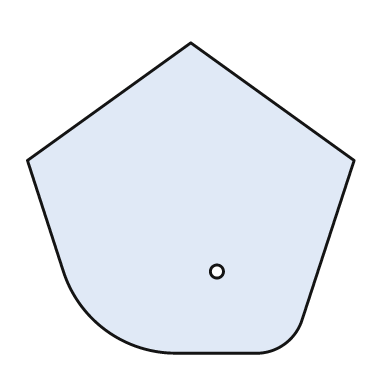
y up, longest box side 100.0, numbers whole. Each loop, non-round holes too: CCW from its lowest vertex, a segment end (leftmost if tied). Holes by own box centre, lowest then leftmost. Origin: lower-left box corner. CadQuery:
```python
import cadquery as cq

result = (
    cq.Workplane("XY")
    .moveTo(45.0, 0.0)
    .lineTo(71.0, 0.0)
    .threePointArc((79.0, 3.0), (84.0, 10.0))
    .lineTo(100.0, 59.0)
    .lineTo(50.0, 95.0)
    .lineTo(0.0, 59.0)
    .lineTo(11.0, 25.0)
    .threePointArc((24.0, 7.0), (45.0, 0.0))
    .close()
    .moveTo(58.0, 25.0)
    .circle(2.0)
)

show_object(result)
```